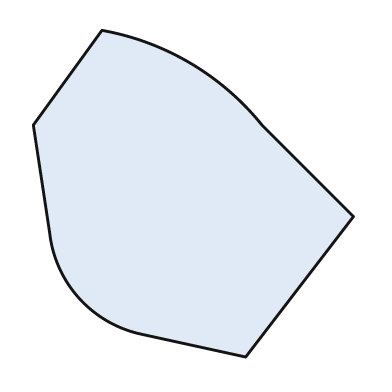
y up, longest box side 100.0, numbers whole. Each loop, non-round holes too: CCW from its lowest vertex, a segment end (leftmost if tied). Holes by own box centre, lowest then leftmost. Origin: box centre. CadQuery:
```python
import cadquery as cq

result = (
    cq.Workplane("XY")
    .moveTo(16.0, -50.0)
    .lineTo(49.0, -7.0)
    .lineTo(21.0, 21.0)
    .threePointArc((-1.0, 40.0), (-28.0, 50.0))
    .lineTo(-49.0, 21.0)
    .lineTo(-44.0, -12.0)
    .threePointArc((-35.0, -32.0), (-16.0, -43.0))
    .close()
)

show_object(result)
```